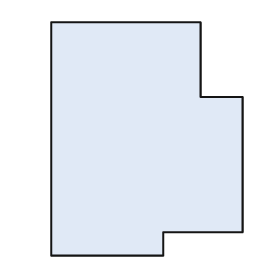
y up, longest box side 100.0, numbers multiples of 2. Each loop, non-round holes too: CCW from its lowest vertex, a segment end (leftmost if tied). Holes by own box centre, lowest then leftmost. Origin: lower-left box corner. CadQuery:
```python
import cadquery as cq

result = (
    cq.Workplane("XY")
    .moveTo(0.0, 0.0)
    .lineTo(48.0, 0.0)
    .lineTo(48.0, 10.0)
    .lineTo(82.0, 10.0)
    .lineTo(82.0, 68.0)
    .lineTo(64.0, 68.0)
    .lineTo(64.0, 100.0)
    .lineTo(0.0, 100.0)
    .close()
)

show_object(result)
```